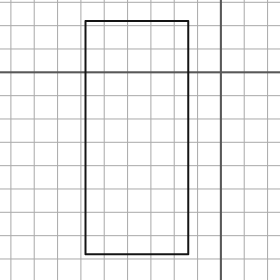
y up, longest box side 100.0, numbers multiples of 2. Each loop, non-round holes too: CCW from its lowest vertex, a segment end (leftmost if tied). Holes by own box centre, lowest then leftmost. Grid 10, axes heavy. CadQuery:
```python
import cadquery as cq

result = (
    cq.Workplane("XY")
    .moveTo(-58.0, -78.0)
    .lineTo(-14.0, -78.0)
    .lineTo(-14.0, 22.0)
    .lineTo(-58.0, 22.0)
    .close()
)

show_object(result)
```